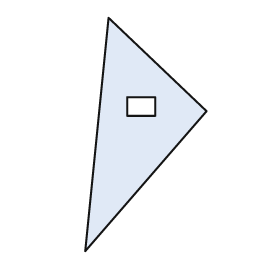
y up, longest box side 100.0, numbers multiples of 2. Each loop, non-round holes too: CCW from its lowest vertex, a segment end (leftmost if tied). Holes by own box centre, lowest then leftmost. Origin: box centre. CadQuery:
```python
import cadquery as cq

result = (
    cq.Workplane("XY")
    .moveTo(-26.0, -50.0)
    .lineTo(26.0, 10.0)
    .lineTo(-16.0, 50.0)
    .close()
    .moveTo(-8.0, 8.0)
    .lineTo(4.0, 8.0)
    .lineTo(4.0, 16.0)
    .lineTo(-8.0, 16.0)
    .close()
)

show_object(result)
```